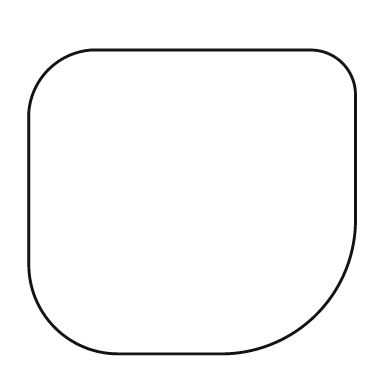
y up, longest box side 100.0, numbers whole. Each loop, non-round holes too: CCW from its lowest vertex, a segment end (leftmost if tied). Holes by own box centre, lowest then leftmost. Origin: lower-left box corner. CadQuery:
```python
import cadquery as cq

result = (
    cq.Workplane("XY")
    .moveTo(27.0, 0.0)
    .lineTo(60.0, 0.0)
    .threePointArc((88.0, 12.0), (100.0, 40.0))
    .lineTo(100.0, 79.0)
    .threePointArc((96.0, 89.0), (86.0, 93.0))
    .lineTo(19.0, 93.0)
    .threePointArc((6.0, 87.0), (0.0, 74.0))
    .lineTo(0.0, 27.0)
    .threePointArc((8.0, 8.0), (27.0, 0.0))
    .close()
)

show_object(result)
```